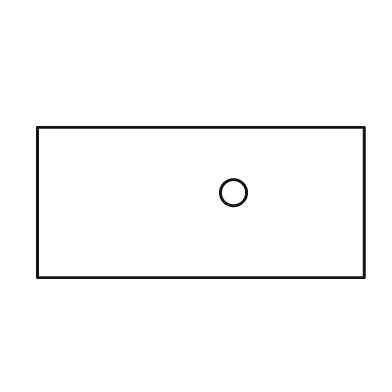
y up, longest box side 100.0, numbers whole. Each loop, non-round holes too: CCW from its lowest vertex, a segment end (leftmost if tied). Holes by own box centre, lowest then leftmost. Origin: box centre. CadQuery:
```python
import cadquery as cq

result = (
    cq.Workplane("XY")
    .moveTo(-50.0, -23.0)
    .lineTo(50.0, -23.0)
    .lineTo(50.0, 23.0)
    .lineTo(-50.0, 23.0)
    .close()
    .moveTo(10.0, 3.0)
    .circle(4.0)
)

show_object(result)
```